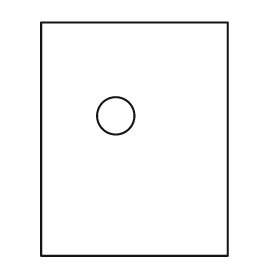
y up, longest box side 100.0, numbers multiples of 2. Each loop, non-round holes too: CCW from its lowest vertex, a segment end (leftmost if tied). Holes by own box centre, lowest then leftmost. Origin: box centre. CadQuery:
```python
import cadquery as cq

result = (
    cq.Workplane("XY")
    .moveTo(-40.0, -50.0)
    .lineTo(40.0, -50.0)
    .lineTo(40.0, 50.0)
    .lineTo(-40.0, 50.0)
    .close()
    .moveTo(-8.0, 10.0)
    .circle(8.0)
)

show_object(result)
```